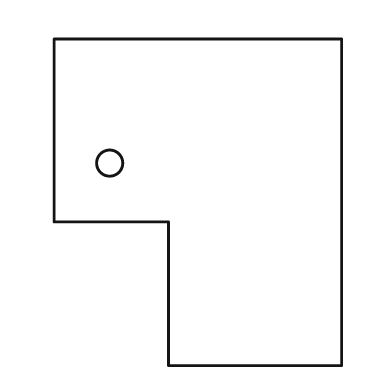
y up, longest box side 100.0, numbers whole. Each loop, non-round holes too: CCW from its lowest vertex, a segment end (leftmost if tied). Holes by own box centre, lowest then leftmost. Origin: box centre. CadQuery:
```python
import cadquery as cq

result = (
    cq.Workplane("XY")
    .moveTo(-9.0, -50.0)
    .lineTo(44.0, -50.0)
    .lineTo(44.0, 50.0)
    .lineTo(-44.0, 50.0)
    .lineTo(-44.0, -6.0)
    .lineTo(-9.0, -6.0)
    .close()
    .moveTo(-27.0, 12.0)
    .circle(4.0)
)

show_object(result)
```